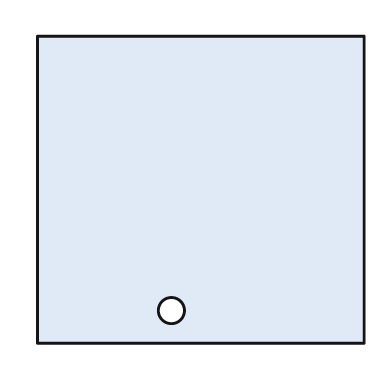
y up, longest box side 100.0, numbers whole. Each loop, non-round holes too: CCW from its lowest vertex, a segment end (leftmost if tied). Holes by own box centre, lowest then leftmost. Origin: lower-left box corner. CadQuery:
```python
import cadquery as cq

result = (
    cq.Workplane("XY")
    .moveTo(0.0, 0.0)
    .lineTo(100.0, 0.0)
    .lineTo(100.0, 94.0)
    .lineTo(0.0, 94.0)
    .close()
    .moveTo(41.0, 10.0)
    .circle(4.0)
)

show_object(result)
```